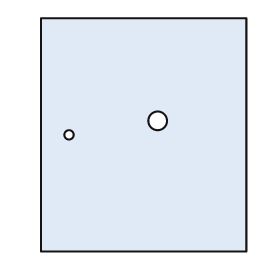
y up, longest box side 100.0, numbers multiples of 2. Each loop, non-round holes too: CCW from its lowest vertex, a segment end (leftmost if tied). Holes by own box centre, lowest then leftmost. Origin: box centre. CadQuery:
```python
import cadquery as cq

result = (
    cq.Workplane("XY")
    .moveTo(-44.0, -50.0)
    .lineTo(44.0, -50.0)
    .lineTo(44.0, 50.0)
    .lineTo(-44.0, 50.0)
    .close()
    .moveTo(-32.0, 0.0)
    .circle(2.0)
    .moveTo(6.0, 6.0)
    .circle(4.0)
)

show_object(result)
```